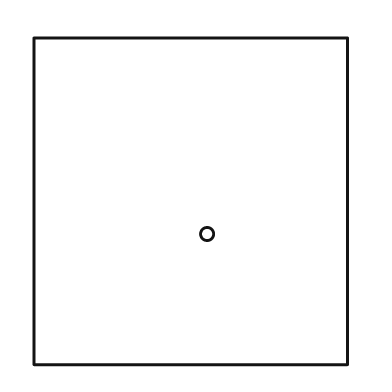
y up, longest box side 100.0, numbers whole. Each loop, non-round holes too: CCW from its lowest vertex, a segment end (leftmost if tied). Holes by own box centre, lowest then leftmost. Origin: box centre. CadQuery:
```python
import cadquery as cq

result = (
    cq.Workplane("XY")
    .moveTo(-48.0, -50.0)
    .lineTo(48.0, -50.0)
    .lineTo(48.0, 50.0)
    .lineTo(-48.0, 50.0)
    .close()
    .moveTo(5.0, -10.0)
    .circle(2.0)
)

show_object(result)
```